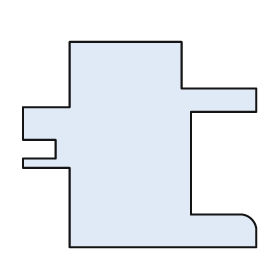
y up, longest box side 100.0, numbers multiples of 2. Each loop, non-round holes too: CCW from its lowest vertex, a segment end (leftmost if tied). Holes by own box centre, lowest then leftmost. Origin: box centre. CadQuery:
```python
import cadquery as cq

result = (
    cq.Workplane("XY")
    .moveTo(-30.0, -44.0)
    .lineTo(50.0, -44.0)
    .lineTo(50.0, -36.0)
    .threePointArc((48.0, -32.0), (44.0, -30.0))
    .lineTo(22.0, -30.0)
    .lineTo(22.0, 14.0)
    .lineTo(50.0, 14.0)
    .lineTo(50.0, 24.0)
    .lineTo(18.0, 24.0)
    .lineTo(18.0, 44.0)
    .lineTo(-30.0, 44.0)
    .lineTo(-30.0, 16.0)
    .lineTo(-50.0, 16.0)
    .lineTo(-50.0, 2.0)
    .lineTo(-36.0, 2.0)
    .lineTo(-36.0, -6.0)
    .lineTo(-50.0, -6.0)
    .lineTo(-50.0, -10.0)
    .lineTo(-30.0, -10.0)
    .close()
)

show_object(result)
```